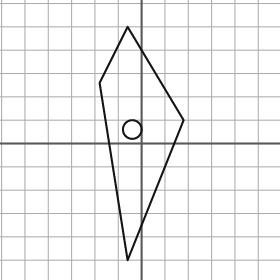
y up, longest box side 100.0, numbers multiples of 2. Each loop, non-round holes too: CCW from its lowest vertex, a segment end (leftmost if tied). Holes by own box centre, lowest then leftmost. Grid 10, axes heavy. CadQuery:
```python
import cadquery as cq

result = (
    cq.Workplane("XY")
    .moveTo(-6.0, -50.0)
    .lineTo(18.0, 10.0)
    .lineTo(-6.0, 50.0)
    .lineTo(-18.0, 26.0)
    .close()
    .moveTo(-4.0, 6.0)
    .circle(4.0)
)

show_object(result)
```